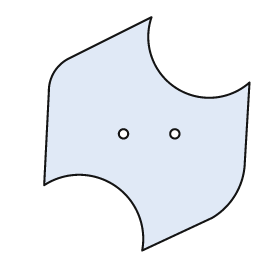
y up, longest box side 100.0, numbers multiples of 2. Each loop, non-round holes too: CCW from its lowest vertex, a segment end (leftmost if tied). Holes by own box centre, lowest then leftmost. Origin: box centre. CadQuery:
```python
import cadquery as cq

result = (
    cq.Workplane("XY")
    .moveTo(-2.0, -50.0)
    .lineTo(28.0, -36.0)
    .threePointArc((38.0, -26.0), (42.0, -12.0))
    .lineTo(44.0, 22.0)
    .threePointArc((12.0, 20.0), (2.0, 50.0))
    .lineTo(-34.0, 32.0)
    .threePointArc((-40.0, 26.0), (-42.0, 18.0))
    .lineTo(-44.0, -22.0)
    .threePointArc((-14.0, -22.0), (-2.0, -50.0))
    .close()
    .moveTo(-10.0, 0.0)
    .circle(2.0)
    .moveTo(12.0, 0.0)
    .circle(2.0)
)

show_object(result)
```